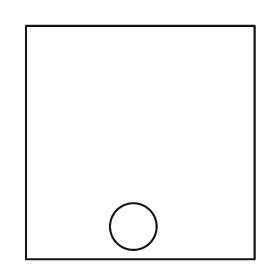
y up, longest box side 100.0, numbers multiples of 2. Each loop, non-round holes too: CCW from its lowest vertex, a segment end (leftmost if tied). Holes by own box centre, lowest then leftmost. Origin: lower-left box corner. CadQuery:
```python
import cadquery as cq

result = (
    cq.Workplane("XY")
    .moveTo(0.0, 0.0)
    .lineTo(98.0, 0.0)
    .lineTo(98.0, 100.0)
    .lineTo(0.0, 100.0)
    .close()
    .moveTo(46.0, 14.0)
    .circle(10.0)
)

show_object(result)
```